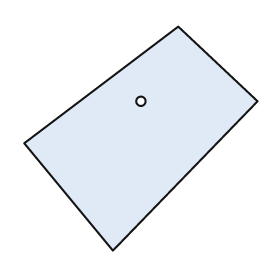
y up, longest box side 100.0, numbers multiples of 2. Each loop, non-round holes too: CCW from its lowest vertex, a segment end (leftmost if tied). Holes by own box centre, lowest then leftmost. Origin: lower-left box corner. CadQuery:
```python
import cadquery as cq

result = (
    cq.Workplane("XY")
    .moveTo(38.0, 0.0)
    .lineTo(100.0, 64.0)
    .lineTo(66.0, 96.0)
    .lineTo(0.0, 46.0)
    .close()
    .moveTo(50.0, 64.0)
    .circle(2.0)
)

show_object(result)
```